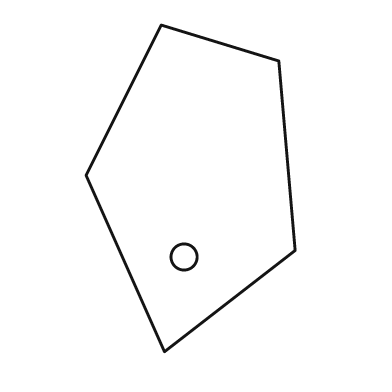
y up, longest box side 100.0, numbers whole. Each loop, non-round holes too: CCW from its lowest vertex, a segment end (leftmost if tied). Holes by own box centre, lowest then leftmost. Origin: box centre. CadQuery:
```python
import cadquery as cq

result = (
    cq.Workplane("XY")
    .moveTo(-8.0, -50.0)
    .lineTo(32.0, -19.0)
    .lineTo(27.0, 39.0)
    .lineTo(-9.0, 50.0)
    .lineTo(-32.0, 4.0)
    .close()
    .moveTo(-2.0, -21.0)
    .circle(4.0)
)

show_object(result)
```